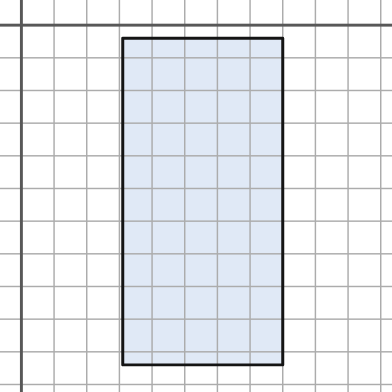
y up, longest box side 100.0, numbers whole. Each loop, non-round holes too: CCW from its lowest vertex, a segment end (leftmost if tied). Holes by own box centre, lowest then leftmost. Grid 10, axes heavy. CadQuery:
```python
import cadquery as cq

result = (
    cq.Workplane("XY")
    .moveTo(31.0, -104.0)
    .lineTo(80.0, -104.0)
    .lineTo(80.0, -4.0)
    .lineTo(31.0, -4.0)
    .close()
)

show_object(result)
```